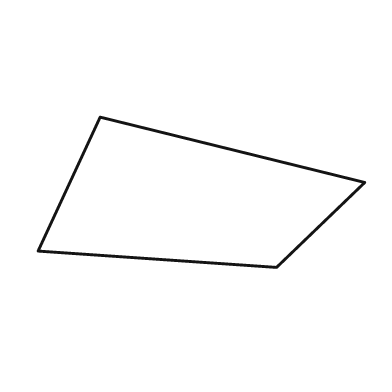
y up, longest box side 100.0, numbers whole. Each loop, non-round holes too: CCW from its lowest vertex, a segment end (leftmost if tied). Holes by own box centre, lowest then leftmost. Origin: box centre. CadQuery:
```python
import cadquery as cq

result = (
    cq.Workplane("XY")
    .moveTo(23.0, -23.0)
    .lineTo(50.0, 3.0)
    .lineTo(-31.0, 23.0)
    .lineTo(-50.0, -18.0)
    .close()
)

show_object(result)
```